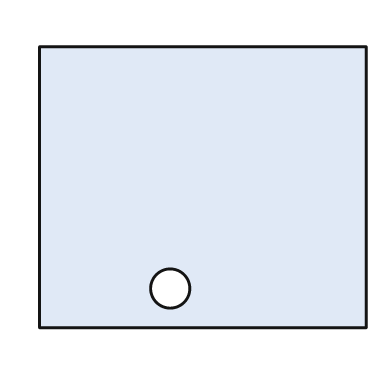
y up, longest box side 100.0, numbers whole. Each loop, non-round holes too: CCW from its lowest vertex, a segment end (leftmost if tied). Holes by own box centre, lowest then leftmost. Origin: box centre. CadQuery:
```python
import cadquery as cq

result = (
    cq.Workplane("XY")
    .moveTo(-50.0, -43.0)
    .lineTo(50.0, -43.0)
    .lineTo(50.0, 43.0)
    .lineTo(-50.0, 43.0)
    .close()
    .moveTo(-10.0, -31.0)
    .circle(6.0)
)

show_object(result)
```